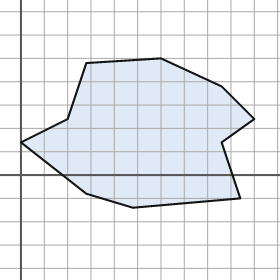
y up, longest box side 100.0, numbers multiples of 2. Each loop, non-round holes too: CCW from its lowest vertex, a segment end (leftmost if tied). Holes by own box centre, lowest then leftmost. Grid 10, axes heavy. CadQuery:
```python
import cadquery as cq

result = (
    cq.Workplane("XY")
    .moveTo(48.0, -14.0)
    .lineTo(94.0, -10.0)
    .lineTo(86.0, 14.0)
    .lineTo(100.0, 24.0)
    .lineTo(86.0, 38.0)
    .lineTo(60.0, 50.0)
    .lineTo(28.0, 48.0)
    .lineTo(20.0, 24.0)
    .lineTo(0.0, 14.0)
    .lineTo(28.0, -8.0)
    .close()
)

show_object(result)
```